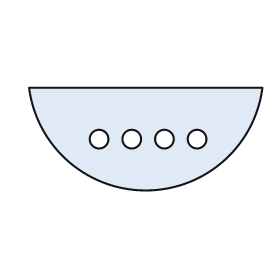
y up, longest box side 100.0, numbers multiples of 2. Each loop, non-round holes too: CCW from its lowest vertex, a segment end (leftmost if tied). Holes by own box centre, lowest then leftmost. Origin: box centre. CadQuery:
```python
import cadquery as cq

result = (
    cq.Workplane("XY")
    .moveTo(-50.0, 22.0)
    .threePointArc((0.0, -22.0), (50.0, 22.0))
    .close()
    .moveTo(-20.0, 0.0)
    .circle(4.0)
    .moveTo(-6.0, 0.0)
    .circle(4.0)
    .moveTo(8.0, 0.0)
    .circle(4.0)
    .moveTo(22.0, 0.0)
    .circle(4.0)
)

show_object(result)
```